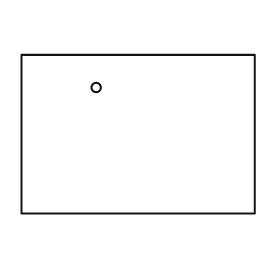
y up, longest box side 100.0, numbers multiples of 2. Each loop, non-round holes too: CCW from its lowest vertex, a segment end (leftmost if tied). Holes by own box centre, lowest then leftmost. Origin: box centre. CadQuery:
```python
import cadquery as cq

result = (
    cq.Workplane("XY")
    .moveTo(-50.0, -34.0)
    .lineTo(50.0, -34.0)
    .lineTo(50.0, 34.0)
    .lineTo(-50.0, 34.0)
    .close()
    .moveTo(-18.0, 20.0)
    .circle(2.0)
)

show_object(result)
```